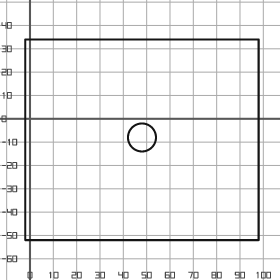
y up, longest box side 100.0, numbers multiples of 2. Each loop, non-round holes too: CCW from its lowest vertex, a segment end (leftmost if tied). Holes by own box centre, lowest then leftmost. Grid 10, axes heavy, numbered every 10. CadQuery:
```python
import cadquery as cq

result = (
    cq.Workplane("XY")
    .moveTo(-2.0, -52.0)
    .lineTo(98.0, -52.0)
    .lineTo(98.0, 34.0)
    .lineTo(-2.0, 34.0)
    .close()
    .moveTo(48.0, -8.0)
    .circle(6.0)
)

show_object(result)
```